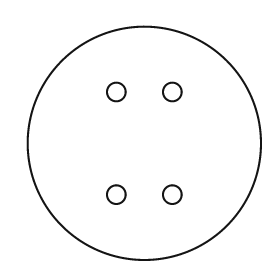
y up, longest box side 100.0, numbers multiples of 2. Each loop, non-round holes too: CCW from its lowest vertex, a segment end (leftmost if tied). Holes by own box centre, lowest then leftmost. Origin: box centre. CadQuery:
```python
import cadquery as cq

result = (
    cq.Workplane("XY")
    .moveTo(0.0, 0.0)
    .circle(50.0)
    .moveTo(-12.0, -22.0)
    .circle(4.0)
    .moveTo(12.0, -22.0)
    .circle(4.0)
    .moveTo(-12.0, 22.0)
    .circle(4.0)
    .moveTo(12.0, 22.0)
    .circle(4.0)
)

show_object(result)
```